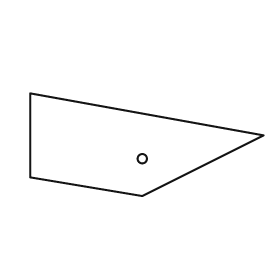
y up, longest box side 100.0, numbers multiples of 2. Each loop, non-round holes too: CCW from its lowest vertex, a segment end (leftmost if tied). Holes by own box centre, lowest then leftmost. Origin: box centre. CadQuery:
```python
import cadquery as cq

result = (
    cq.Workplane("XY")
    .moveTo(-2.0, -22.0)
    .lineTo(50.0, 4.0)
    .lineTo(-50.0, 22.0)
    .lineTo(-50.0, -14.0)
    .close()
    .moveTo(-2.0, -6.0)
    .circle(2.0)
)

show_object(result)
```